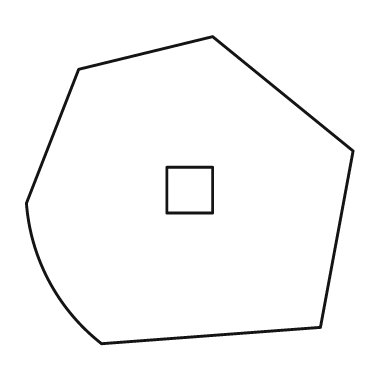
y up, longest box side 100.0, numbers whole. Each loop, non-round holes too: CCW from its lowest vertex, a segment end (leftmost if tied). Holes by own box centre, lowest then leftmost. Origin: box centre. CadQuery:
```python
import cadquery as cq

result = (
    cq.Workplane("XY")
    .moveTo(-27.0, -47.0)
    .lineTo(40.0, -42.0)
    .lineTo(50.0, 12.0)
    .lineTo(7.0, 47.0)
    .lineTo(-34.0, 37.0)
    .lineTo(-50.0, -4.0)
    .threePointArc((-43.0, -28.0), (-27.0, -47.0))
    .close()
    .moveTo(-7.0, -7.0)
    .lineTo(7.0, -7.0)
    .lineTo(7.0, 7.0)
    .lineTo(-7.0, 7.0)
    .close()
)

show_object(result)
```